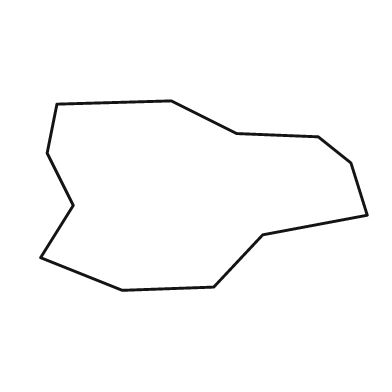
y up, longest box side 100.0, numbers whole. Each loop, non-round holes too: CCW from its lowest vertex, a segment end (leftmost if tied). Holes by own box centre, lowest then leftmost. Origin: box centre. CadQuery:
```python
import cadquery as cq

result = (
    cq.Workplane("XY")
    .moveTo(-25.0, -29.0)
    .lineTo(3.0, -28.0)
    .lineTo(18.0, -12.0)
    .lineTo(50.0, -6.0)
    .lineTo(45.0, 10.0)
    .lineTo(35.0, 18.0)
    .lineTo(10.0, 19.0)
    .lineTo(-10.0, 29.0)
    .lineTo(-45.0, 28.0)
    .lineTo(-48.0, 13.0)
    .lineTo(-40.0, -3.0)
    .lineTo(-50.0, -19.0)
    .close()
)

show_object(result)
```